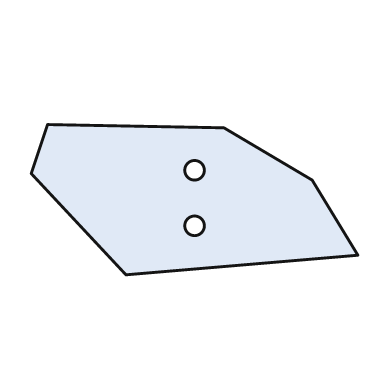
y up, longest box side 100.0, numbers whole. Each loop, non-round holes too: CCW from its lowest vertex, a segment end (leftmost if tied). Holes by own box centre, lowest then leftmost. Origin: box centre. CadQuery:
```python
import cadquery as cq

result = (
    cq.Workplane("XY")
    .moveTo(-21.0, -23.0)
    .lineTo(50.0, -17.0)
    .lineTo(36.0, 6.0)
    .lineTo(9.0, 22.0)
    .lineTo(-45.0, 23.0)
    .lineTo(-50.0, 8.0)
    .close()
    .moveTo(0.0, -8.0)
    .circle(3.0)
    .moveTo(0.0, 9.0)
    .circle(3.0)
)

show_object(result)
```